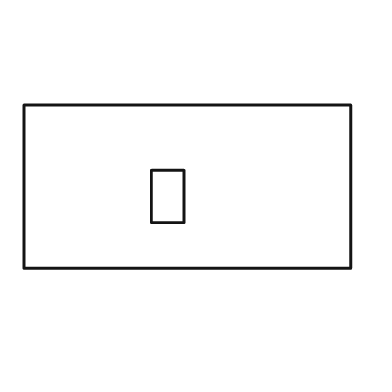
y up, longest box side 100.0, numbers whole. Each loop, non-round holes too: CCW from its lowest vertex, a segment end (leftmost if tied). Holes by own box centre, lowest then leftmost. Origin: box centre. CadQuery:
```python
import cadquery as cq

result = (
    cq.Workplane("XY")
    .moveTo(-50.0, -25.0)
    .lineTo(50.0, -25.0)
    .lineTo(50.0, 25.0)
    .lineTo(-50.0, 25.0)
    .close()
    .moveTo(-11.0, -11.0)
    .lineTo(-1.0, -11.0)
    .lineTo(-1.0, 5.0)
    .lineTo(-11.0, 5.0)
    .close()
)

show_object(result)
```